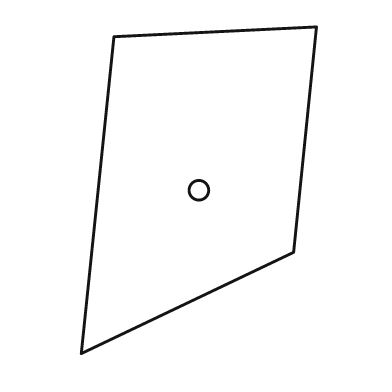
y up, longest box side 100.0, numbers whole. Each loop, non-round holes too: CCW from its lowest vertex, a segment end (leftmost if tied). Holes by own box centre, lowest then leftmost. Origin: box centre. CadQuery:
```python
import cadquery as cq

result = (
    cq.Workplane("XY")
    .moveTo(-36.0, -50.0)
    .lineTo(29.0, -19.0)
    .lineTo(36.0, 50.0)
    .lineTo(-26.0, 47.0)
    .close()
    .moveTo(0.0, 0.0)
    .circle(3.0)
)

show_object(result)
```